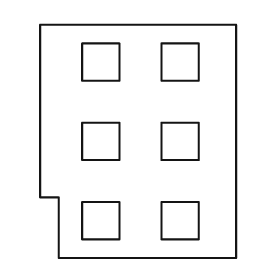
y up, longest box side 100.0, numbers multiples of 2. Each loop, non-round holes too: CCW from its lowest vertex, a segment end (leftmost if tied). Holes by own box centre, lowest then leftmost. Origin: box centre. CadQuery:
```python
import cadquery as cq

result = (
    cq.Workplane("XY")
    .moveTo(-34.0, -50.0)
    .lineTo(42.0, -50.0)
    .lineTo(42.0, 50.0)
    .lineTo(-42.0, 50.0)
    .lineTo(-42.0, -24.0)
    .lineTo(-34.0, -24.0)
    .close()
    .moveTo(-24.0, -42.0)
    .lineTo(-8.0, -42.0)
    .lineTo(-8.0, -26.0)
    .lineTo(-24.0, -26.0)
    .close()
    .moveTo(10.0, -42.0)
    .lineTo(26.0, -42.0)
    .lineTo(26.0, -26.0)
    .lineTo(10.0, -26.0)
    .close()
    .moveTo(-24.0, -8.0)
    .lineTo(-8.0, -8.0)
    .lineTo(-8.0, 8.0)
    .lineTo(-24.0, 8.0)
    .close()
    .moveTo(10.0, -8.0)
    .lineTo(26.0, -8.0)
    .lineTo(26.0, 8.0)
    .lineTo(10.0, 8.0)
    .close()
    .moveTo(-24.0, 26.0)
    .lineTo(-8.0, 26.0)
    .lineTo(-8.0, 42.0)
    .lineTo(-24.0, 42.0)
    .close()
    .moveTo(10.0, 26.0)
    .lineTo(26.0, 26.0)
    .lineTo(26.0, 42.0)
    .lineTo(10.0, 42.0)
    .close()
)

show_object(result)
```